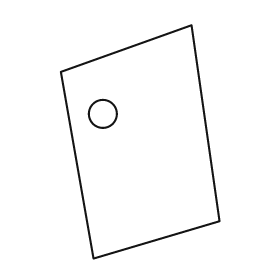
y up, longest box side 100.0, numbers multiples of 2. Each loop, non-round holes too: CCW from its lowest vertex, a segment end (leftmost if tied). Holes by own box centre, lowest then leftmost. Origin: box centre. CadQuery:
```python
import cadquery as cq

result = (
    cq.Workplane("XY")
    .moveTo(-20.0, -50.0)
    .lineTo(34.0, -34.0)
    .lineTo(22.0, 50.0)
    .lineTo(-34.0, 30.0)
    .close()
    .moveTo(-16.0, 12.0)
    .circle(6.0)
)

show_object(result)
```